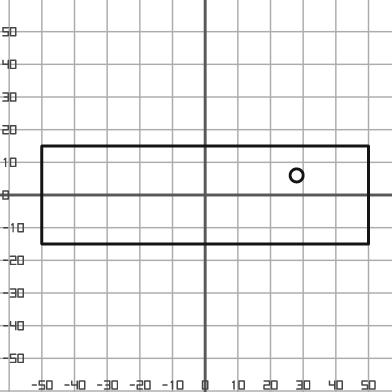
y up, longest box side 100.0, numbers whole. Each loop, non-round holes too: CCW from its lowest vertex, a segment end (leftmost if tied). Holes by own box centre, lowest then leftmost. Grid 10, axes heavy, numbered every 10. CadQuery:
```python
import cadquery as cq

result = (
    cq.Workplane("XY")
    .moveTo(-50.0, -15.0)
    .lineTo(50.0, -15.0)
    .lineTo(50.0, 15.0)
    .lineTo(-50.0, 15.0)
    .close()
    .moveTo(28.0, 6.0)
    .circle(2.0)
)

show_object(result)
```